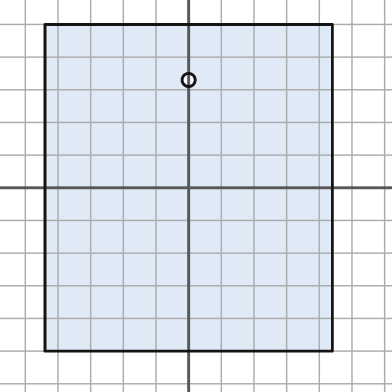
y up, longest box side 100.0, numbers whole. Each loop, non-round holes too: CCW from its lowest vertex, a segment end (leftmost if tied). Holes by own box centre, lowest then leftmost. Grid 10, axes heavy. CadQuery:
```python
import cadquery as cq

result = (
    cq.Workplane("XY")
    .moveTo(-44.0, -50.0)
    .lineTo(44.0, -50.0)
    .lineTo(44.0, 50.0)
    .lineTo(-44.0, 50.0)
    .close()
    .moveTo(0.0, 33.0)
    .circle(2.0)
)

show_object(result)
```